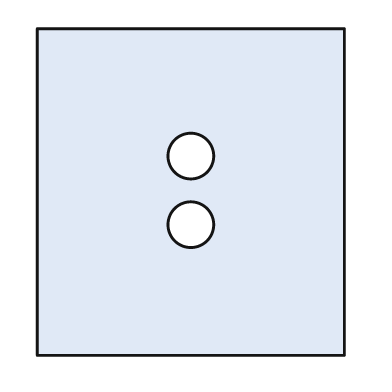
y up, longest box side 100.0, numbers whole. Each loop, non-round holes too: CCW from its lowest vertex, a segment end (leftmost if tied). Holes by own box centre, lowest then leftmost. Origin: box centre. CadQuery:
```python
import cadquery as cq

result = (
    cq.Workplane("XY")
    .moveTo(-47.0, -50.0)
    .lineTo(47.0, -50.0)
    .lineTo(47.0, 50.0)
    .lineTo(-47.0, 50.0)
    .close()
    .moveTo(0.0, -10.0)
    .circle(7.0)
    .moveTo(0.0, 11.0)
    .circle(7.0)
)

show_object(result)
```